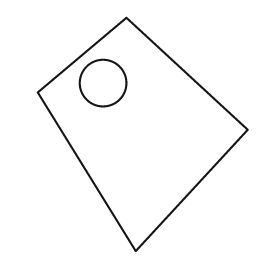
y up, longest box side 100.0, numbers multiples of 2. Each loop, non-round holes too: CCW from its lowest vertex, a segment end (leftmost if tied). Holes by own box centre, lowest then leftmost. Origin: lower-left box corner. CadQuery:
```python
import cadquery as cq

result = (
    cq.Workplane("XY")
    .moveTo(42.0, 0.0)
    .lineTo(90.0, 52.0)
    .lineTo(38.0, 100.0)
    .lineTo(0.0, 68.0)
    .close()
    .moveTo(28.0, 72.0)
    .circle(10.0)
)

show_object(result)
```